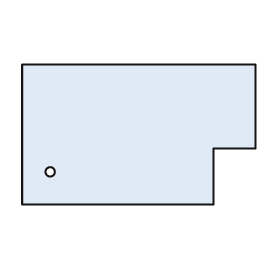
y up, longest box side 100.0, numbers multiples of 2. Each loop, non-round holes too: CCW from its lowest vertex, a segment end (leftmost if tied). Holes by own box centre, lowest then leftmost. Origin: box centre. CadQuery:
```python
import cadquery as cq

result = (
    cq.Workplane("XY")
    .moveTo(-50.0, -30.0)
    .lineTo(32.0, -30.0)
    .lineTo(32.0, -6.0)
    .lineTo(50.0, -6.0)
    .lineTo(50.0, 30.0)
    .lineTo(-50.0, 30.0)
    .close()
    .moveTo(-38.0, -16.0)
    .circle(2.0)
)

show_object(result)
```